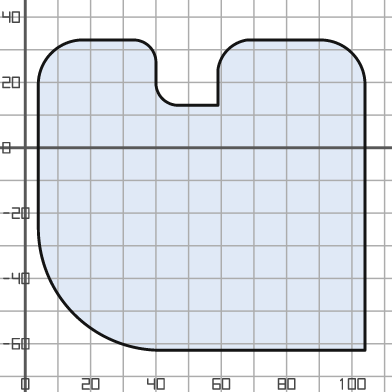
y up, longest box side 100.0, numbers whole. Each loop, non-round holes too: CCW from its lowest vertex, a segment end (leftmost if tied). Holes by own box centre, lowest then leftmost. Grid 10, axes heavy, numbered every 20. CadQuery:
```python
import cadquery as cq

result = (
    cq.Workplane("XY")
    .moveTo(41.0, -62.0)
    .lineTo(104.0, -62.0)
    .lineTo(104.0, 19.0)
    .threePointArc((100.0, 29.0), (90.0, 33.0))
    .lineTo(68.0, 33.0)
    .threePointArc((62.0, 30.0), (59.0, 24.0))
    .lineTo(59.0, 13.0)
    .lineTo(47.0, 13.0)
    .threePointArc((42.0, 15.0), (40.0, 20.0))
    .lineTo(40.0, 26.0)
    .threePointArc((38.0, 31.0), (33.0, 33.0))
    .lineTo(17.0, 33.0)
    .threePointArc((8.0, 29.0), (4.0, 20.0))
    .lineTo(4.0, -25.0)
    .threePointArc((15.0, -51.0), (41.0, -62.0))
    .close()
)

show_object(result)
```